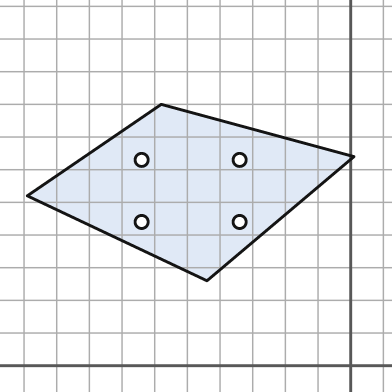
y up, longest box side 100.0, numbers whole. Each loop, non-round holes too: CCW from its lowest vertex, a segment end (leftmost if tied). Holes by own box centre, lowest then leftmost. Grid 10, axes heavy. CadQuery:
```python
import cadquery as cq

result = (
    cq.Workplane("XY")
    .moveTo(-44.0, 26.0)
    .lineTo(1.0, 64.0)
    .lineTo(-58.0, 80.0)
    .lineTo(-99.0, 52.0)
    .close()
    .moveTo(-64.0, 44.0)
    .circle(2.0)
    .moveTo(-34.0, 44.0)
    .circle(2.0)
    .moveTo(-64.0, 63.0)
    .circle(2.0)
    .moveTo(-34.0, 63.0)
    .circle(2.0)
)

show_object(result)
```